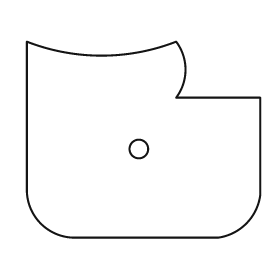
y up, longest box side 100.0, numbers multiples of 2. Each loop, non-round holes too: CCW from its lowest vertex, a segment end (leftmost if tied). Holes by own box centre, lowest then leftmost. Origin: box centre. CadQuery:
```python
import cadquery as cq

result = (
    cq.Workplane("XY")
    .moveTo(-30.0, -42.0)
    .lineTo(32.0, -42.0)
    .threePointArc((44.0, -36.0), (50.0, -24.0))
    .lineTo(50.0, 18.0)
    .lineTo(14.0, 18.0)
    .threePointArc((18.0, 30.0), (14.0, 42.0))
    .threePointArc((-18.0, 36.0), (-50.0, 42.0))
    .lineTo(-50.0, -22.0)
    .threePointArc((-44.0, -36.0), (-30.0, -42.0))
    .close()
    .moveTo(-2.0, -4.0)
    .circle(4.0)
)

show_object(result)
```